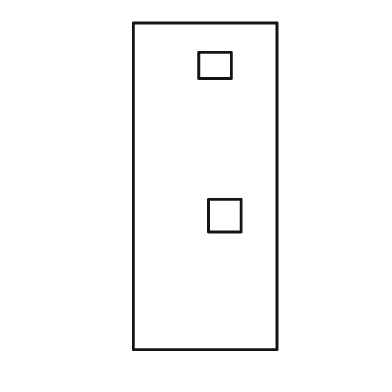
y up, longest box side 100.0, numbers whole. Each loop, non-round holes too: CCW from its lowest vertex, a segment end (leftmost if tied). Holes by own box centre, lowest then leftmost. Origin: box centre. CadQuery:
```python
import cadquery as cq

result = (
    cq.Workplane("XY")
    .moveTo(-22.0, -50.0)
    .lineTo(22.0, -50.0)
    .lineTo(22.0, 50.0)
    .lineTo(-22.0, 50.0)
    .close()
    .moveTo(1.0, -14.0)
    .lineTo(11.0, -14.0)
    .lineTo(11.0, -4.0)
    .lineTo(1.0, -4.0)
    .close()
    .moveTo(-2.0, 33.0)
    .lineTo(8.0, 33.0)
    .lineTo(8.0, 41.0)
    .lineTo(-2.0, 41.0)
    .close()
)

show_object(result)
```